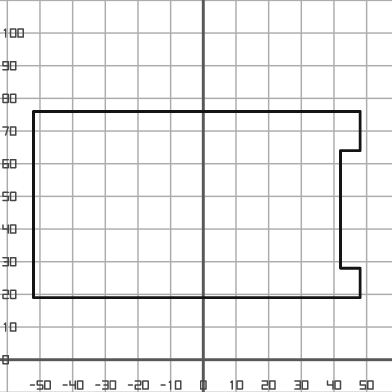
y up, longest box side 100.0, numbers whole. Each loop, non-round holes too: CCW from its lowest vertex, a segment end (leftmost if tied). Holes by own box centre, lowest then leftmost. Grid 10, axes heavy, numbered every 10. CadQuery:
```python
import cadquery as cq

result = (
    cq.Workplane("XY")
    .moveTo(-52.0, 19.0)
    .lineTo(48.0, 19.0)
    .lineTo(48.0, 28.0)
    .lineTo(42.0, 28.0)
    .lineTo(42.0, 64.0)
    .lineTo(48.0, 64.0)
    .lineTo(48.0, 76.0)
    .lineTo(-52.0, 76.0)
    .close()
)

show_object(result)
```